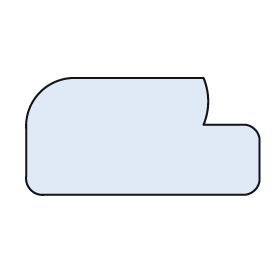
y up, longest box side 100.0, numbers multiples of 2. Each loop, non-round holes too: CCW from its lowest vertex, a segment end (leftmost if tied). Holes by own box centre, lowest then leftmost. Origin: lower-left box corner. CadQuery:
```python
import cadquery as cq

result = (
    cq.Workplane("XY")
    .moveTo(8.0, 0.0)
    .lineTo(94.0, 0.0)
    .threePointArc((98.0, 2.0), (100.0, 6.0))
    .lineTo(100.0, 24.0)
    .threePointArc((98.0, 28.0), (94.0, 30.0))
    .lineTo(76.0, 30.0)
    .threePointArc((78.0, 40.0), (76.0, 50.0))
    .lineTo(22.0, 50.0)
    .threePointArc((6.0, 44.0), (0.0, 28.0))
    .lineTo(0.0, 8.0)
    .threePointArc((2.0, 2.0), (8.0, 0.0))
    .close()
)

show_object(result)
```